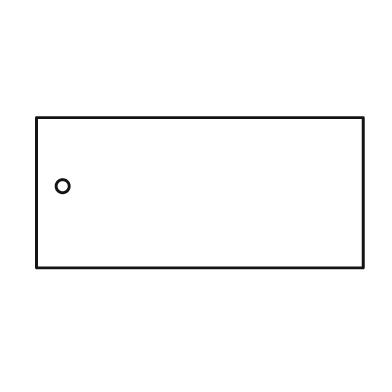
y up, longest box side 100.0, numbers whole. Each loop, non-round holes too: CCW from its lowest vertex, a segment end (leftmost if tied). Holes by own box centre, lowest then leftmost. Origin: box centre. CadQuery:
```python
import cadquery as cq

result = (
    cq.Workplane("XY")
    .moveTo(-50.0, -23.0)
    .lineTo(50.0, -23.0)
    .lineTo(50.0, 23.0)
    .lineTo(-50.0, 23.0)
    .close()
    .moveTo(-42.0, 2.0)
    .circle(2.0)
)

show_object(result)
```